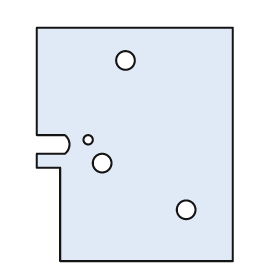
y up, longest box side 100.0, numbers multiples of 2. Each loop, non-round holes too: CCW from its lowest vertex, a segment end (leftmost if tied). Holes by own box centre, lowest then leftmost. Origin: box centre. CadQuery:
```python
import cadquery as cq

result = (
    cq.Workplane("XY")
    .moveTo(-32.0, -50.0)
    .lineTo(42.0, -50.0)
    .lineTo(42.0, 50.0)
    .lineTo(-42.0, 50.0)
    .lineTo(-42.0, 4.0)
    .lineTo(-30.0, 4.0)
    .threePointArc((-28.0, 0.0), (-30.0, -4.0))
    .lineTo(-42.0, -4.0)
    .lineTo(-42.0, -10.0)
    .lineTo(-32.0, -10.0)
    .close()
    .moveTo(22.0, -28.0)
    .circle(4.0)
    .moveTo(-14.0, -8.0)
    .circle(4.0)
    .moveTo(-20.0, 2.0)
    .circle(2.0)
    .moveTo(-4.0, 36.0)
    .circle(4.0)
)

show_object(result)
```